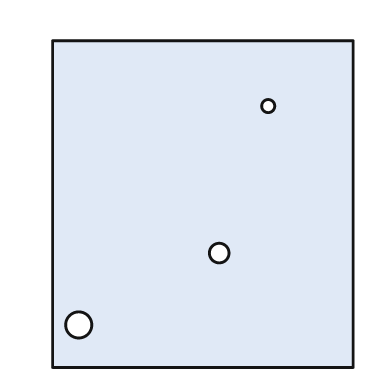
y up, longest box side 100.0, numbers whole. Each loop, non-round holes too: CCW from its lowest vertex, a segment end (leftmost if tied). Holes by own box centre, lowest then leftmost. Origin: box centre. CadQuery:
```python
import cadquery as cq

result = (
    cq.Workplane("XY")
    .moveTo(-46.0, -50.0)
    .lineTo(46.0, -50.0)
    .lineTo(46.0, 50.0)
    .lineTo(-46.0, 50.0)
    .close()
    .moveTo(-38.0, -37.0)
    .circle(4.0)
    .moveTo(5.0, -15.0)
    .circle(3.0)
    .moveTo(20.0, 30.0)
    .circle(2.0)
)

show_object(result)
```